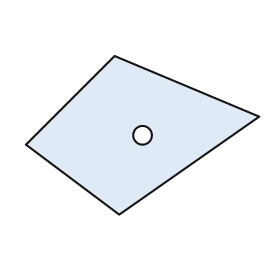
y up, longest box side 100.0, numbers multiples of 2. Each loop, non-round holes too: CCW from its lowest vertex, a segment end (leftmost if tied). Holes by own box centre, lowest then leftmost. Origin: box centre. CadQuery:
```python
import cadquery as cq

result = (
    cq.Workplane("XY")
    .moveTo(-10.0, -34.0)
    .lineTo(50.0, 8.0)
    .lineTo(-12.0, 34.0)
    .lineTo(-50.0, -4.0)
    .close()
    .moveTo(0.0, 0.0)
    .circle(4.0)
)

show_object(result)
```